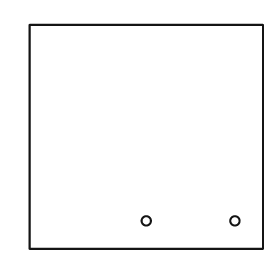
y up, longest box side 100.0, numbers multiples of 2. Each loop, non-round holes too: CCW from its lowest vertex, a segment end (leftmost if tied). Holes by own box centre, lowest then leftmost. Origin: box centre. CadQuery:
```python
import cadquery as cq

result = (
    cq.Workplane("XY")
    .moveTo(-50.0, -48.0)
    .lineTo(50.0, -48.0)
    .lineTo(50.0, 48.0)
    .lineTo(-50.0, 48.0)
    .close()
    .moveTo(0.0, -36.0)
    .circle(2.0)
    .moveTo(38.0, -36.0)
    .circle(2.0)
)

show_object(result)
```